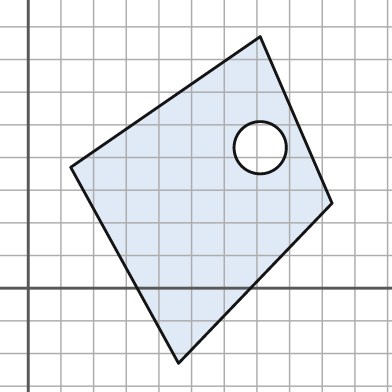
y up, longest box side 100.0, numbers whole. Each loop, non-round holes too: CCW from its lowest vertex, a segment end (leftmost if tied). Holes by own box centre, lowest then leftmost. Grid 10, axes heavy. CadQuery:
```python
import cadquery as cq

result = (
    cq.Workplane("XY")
    .moveTo(46.0, -23.0)
    .lineTo(93.0, 26.0)
    .lineTo(71.0, 77.0)
    .lineTo(13.0, 37.0)
    .close()
    .moveTo(71.0, 43.0)
    .circle(8.0)
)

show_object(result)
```